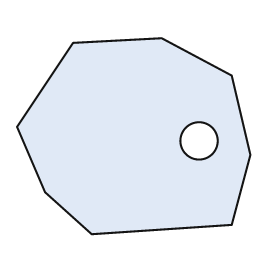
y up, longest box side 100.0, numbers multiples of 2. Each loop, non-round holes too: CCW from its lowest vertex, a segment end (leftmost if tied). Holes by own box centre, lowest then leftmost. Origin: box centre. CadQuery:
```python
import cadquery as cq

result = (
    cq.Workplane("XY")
    .moveTo(-18.0, -42.0)
    .lineTo(42.0, -38.0)
    .lineTo(50.0, -8.0)
    .lineTo(42.0, 26.0)
    .lineTo(12.0, 42.0)
    .lineTo(-26.0, 40.0)
    .lineTo(-50.0, 4.0)
    .lineTo(-38.0, -24.0)
    .close()
    .moveTo(28.0, -2.0)
    .circle(8.0)
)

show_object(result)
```